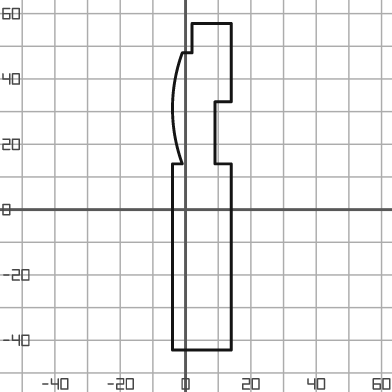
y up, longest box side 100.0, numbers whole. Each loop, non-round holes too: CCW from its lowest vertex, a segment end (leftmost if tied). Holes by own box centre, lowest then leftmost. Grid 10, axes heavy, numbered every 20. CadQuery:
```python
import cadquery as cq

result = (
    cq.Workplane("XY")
    .moveTo(-4.0, -43.0)
    .lineTo(14.0, -43.0)
    .lineTo(14.0, 14.0)
    .lineTo(9.0, 14.0)
    .lineTo(9.0, 33.0)
    .lineTo(14.0, 33.0)
    .lineTo(14.0, 57.0)
    .lineTo(2.0, 57.0)
    .lineTo(2.0, 48.0)
    .lineTo(-1.0, 48.0)
    .threePointArc((-4.0, 31.0), (-1.0, 14.0))
    .lineTo(-4.0, 14.0)
    .close()
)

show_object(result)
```